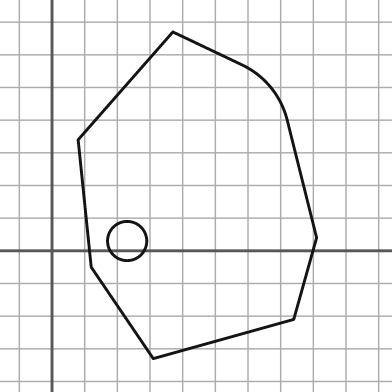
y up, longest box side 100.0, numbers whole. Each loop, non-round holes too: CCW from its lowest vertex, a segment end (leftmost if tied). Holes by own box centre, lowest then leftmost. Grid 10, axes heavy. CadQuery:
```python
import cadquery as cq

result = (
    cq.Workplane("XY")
    .moveTo(31.0, -33.0)
    .lineTo(74.0, -21.0)
    .lineTo(81.0, 4.0)
    .lineTo(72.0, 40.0)
    .threePointArc((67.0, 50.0), (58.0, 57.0))
    .lineTo(37.0, 67.0)
    .lineTo(8.0, 34.0)
    .lineTo(12.0, -5.0)
    .close()
    .moveTo(23.0, 3.0)
    .circle(6.0)
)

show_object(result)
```